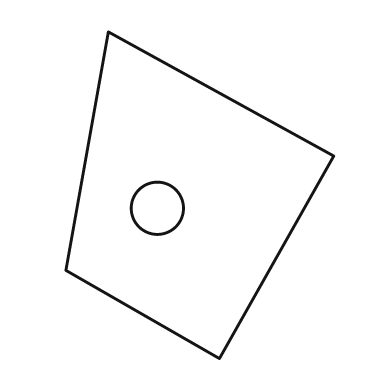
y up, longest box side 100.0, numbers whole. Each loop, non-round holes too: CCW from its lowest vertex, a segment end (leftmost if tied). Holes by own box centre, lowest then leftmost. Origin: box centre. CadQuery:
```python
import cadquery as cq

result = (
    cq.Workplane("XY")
    .moveTo(6.0, -50.0)
    .lineTo(41.0, 12.0)
    .lineTo(-28.0, 50.0)
    .lineTo(-41.0, -23.0)
    .close()
    .moveTo(-13.0, -4.0)
    .circle(8.0)
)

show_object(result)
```